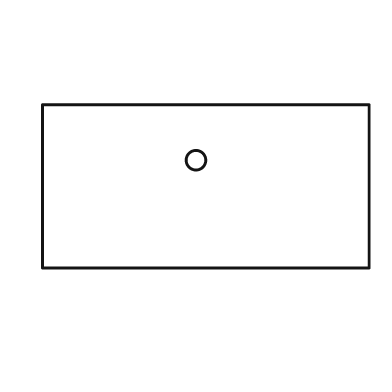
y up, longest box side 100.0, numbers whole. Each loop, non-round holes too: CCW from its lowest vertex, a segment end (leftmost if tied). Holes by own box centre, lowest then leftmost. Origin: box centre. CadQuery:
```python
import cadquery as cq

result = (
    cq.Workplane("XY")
    .moveTo(-50.0, -25.0)
    .lineTo(50.0, -25.0)
    .lineTo(50.0, 25.0)
    .lineTo(-50.0, 25.0)
    .close()
    .moveTo(-3.0, 8.0)
    .circle(3.0)
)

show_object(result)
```